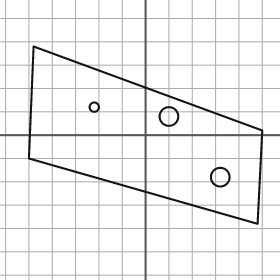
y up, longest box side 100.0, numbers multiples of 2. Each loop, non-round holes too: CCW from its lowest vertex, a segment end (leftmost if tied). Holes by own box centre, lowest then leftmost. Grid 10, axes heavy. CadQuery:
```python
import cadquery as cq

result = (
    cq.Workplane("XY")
    .moveTo(48.0, -38.0)
    .lineTo(50.0, 2.0)
    .lineTo(-48.0, 38.0)
    .lineTo(-50.0, -10.0)
    .close()
    .moveTo(32.0, -18.0)
    .circle(4.0)
    .moveTo(10.0, 8.0)
    .circle(4.0)
    .moveTo(-22.0, 12.0)
    .circle(2.0)
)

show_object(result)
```